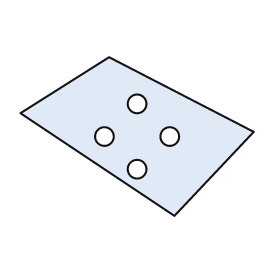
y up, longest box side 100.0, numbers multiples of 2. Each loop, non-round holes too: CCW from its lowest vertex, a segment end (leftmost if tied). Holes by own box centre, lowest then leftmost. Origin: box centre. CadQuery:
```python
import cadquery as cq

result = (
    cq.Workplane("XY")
    .moveTo(16.0, -34.0)
    .lineTo(50.0, 2.0)
    .lineTo(-12.0, 34.0)
    .lineTo(-50.0, 10.0)
    .close()
    .moveTo(0.0, -14.0)
    .circle(4.0)
    .moveTo(-14.0, 0.0)
    .circle(4.0)
    .moveTo(14.0, 0.0)
    .circle(4.0)
    .moveTo(0.0, 14.0)
    .circle(4.0)
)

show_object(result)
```